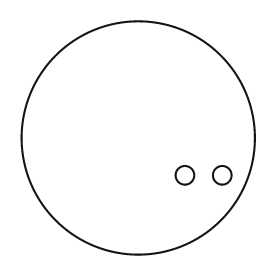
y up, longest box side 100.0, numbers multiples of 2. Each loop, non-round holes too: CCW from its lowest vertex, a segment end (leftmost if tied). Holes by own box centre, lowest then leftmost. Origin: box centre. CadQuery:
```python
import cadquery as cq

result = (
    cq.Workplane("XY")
    .moveTo(0.0, 0.0)
    .circle(50.0)
    .moveTo(20.0, -16.0)
    .circle(4.0)
    .moveTo(36.0, -16.0)
    .circle(4.0)
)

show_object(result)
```